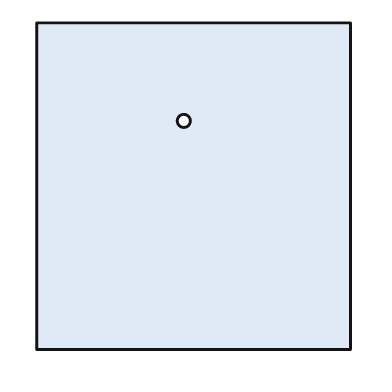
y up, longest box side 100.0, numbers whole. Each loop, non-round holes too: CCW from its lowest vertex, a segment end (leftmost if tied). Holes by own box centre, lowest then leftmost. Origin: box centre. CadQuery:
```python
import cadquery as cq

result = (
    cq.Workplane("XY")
    .moveTo(-48.0, -50.0)
    .lineTo(48.0, -50.0)
    .lineTo(48.0, 50.0)
    .lineTo(-48.0, 50.0)
    .close()
    .moveTo(-3.0, 20.0)
    .circle(2.0)
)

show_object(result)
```